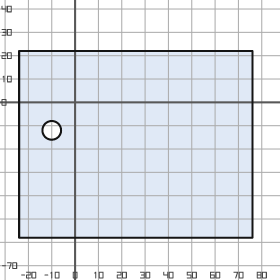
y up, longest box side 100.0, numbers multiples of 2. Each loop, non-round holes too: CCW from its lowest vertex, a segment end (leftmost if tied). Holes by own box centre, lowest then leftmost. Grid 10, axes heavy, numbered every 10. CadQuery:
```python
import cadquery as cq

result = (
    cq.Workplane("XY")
    .moveTo(-24.0, -58.0)
    .lineTo(76.0, -58.0)
    .lineTo(76.0, 22.0)
    .lineTo(-24.0, 22.0)
    .close()
    .moveTo(-10.0, -12.0)
    .circle(4.0)
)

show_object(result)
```